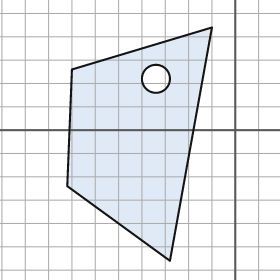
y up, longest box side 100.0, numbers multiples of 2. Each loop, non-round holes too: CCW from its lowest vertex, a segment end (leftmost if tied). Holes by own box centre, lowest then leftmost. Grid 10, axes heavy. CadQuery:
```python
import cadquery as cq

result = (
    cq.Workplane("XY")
    .moveTo(-28.0, -56.0)
    .lineTo(-10.0, 44.0)
    .lineTo(-70.0, 26.0)
    .lineTo(-72.0, -24.0)
    .close()
    .moveTo(-34.0, 22.0)
    .circle(6.0)
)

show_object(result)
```